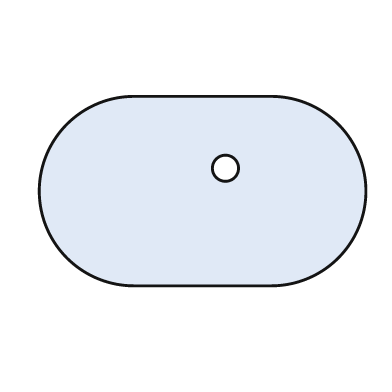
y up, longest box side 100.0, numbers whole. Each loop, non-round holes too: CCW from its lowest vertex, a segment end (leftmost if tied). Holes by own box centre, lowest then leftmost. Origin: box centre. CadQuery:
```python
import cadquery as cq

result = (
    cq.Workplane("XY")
    .moveTo(-21.0, -29.0)
    .lineTo(21.0, -29.0)
    .threePointArc((50.0, 0.0), (21.0, 29.0))
    .lineTo(-21.0, 29.0)
    .threePointArc((-50.0, 0.0), (-21.0, -29.0))
    .close()
    .moveTo(7.0, 7.0)
    .circle(4.0)
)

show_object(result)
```